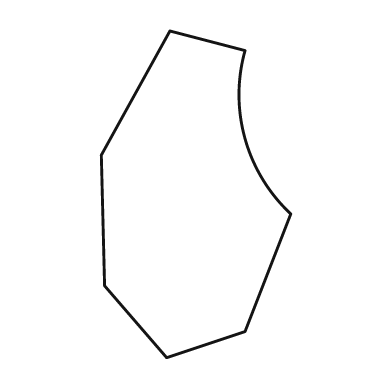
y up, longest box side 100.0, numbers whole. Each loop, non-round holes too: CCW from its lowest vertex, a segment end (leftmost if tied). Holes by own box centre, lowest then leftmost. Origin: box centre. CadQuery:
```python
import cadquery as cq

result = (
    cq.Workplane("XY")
    .moveTo(-9.0, -50.0)
    .lineTo(15.0, -42.0)
    .lineTo(29.0, -6.0)
    .threePointArc((15.0, 17.0), (15.0, 44.0))
    .lineTo(-8.0, 50.0)
    .lineTo(-29.0, 12.0)
    .lineTo(-28.0, -28.0)
    .close()
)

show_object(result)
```